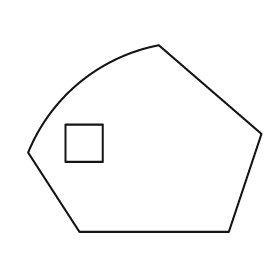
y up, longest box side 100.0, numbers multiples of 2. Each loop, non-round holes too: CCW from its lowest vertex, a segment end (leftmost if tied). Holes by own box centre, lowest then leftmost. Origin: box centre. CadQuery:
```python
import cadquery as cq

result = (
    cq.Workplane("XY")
    .moveTo(-28.0, -40.0)
    .lineTo(36.0, -40.0)
    .lineTo(50.0, 2.0)
    .lineTo(6.0, 40.0)
    .threePointArc((-28.0, 24.0), (-50.0, -6.0))
    .close()
    .moveTo(-34.0, -10.0)
    .lineTo(-18.0, -10.0)
    .lineTo(-18.0, 6.0)
    .lineTo(-34.0, 6.0)
    .close()
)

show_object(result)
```